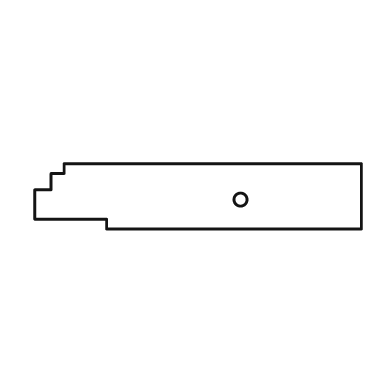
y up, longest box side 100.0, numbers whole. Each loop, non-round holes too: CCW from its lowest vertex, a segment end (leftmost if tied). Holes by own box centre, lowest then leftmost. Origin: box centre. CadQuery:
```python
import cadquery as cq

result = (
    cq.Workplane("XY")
    .moveTo(-28.0, -10.0)
    .lineTo(50.0, -10.0)
    .lineTo(50.0, 10.0)
    .lineTo(-41.0, 10.0)
    .lineTo(-41.0, 7.0)
    .lineTo(-45.0, 7.0)
    .lineTo(-45.0, 2.0)
    .lineTo(-50.0, 2.0)
    .lineTo(-50.0, -7.0)
    .lineTo(-28.0, -7.0)
    .close()
    .moveTo(13.0, -1.0)
    .circle(2.0)
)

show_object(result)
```